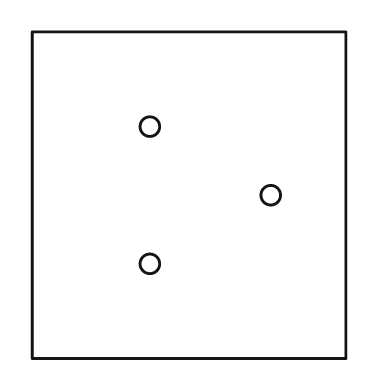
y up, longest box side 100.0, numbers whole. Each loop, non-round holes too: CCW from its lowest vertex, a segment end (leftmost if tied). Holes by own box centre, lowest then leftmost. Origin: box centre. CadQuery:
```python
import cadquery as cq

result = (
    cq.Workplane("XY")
    .moveTo(-48.0, -50.0)
    .lineTo(48.0, -50.0)
    .lineTo(48.0, 50.0)
    .lineTo(-48.0, 50.0)
    .close()
    .moveTo(-12.0, -21.0)
    .circle(3.0)
    .moveTo(25.0, 0.0)
    .circle(3.0)
    .moveTo(-12.0, 21.0)
    .circle(3.0)
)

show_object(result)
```